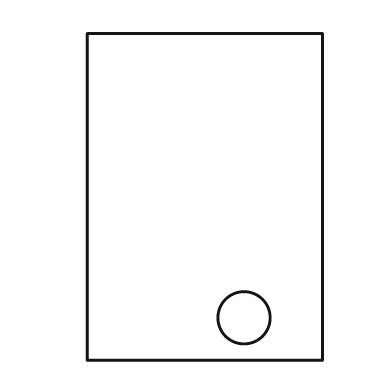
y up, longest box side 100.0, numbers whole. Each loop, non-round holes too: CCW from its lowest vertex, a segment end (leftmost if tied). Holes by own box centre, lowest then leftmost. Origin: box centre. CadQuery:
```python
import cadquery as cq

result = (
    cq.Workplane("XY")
    .moveTo(-36.0, -50.0)
    .lineTo(36.0, -50.0)
    .lineTo(36.0, 50.0)
    .lineTo(-36.0, 50.0)
    .close()
    .moveTo(12.0, -37.0)
    .circle(8.0)
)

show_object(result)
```